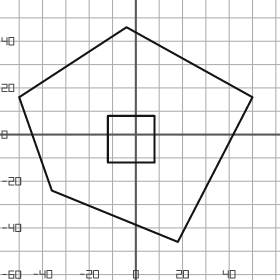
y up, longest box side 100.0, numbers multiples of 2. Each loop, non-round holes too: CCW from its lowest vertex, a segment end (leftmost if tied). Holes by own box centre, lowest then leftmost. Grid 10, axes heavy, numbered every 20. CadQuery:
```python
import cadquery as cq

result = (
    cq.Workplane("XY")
    .moveTo(18.0, -46.0)
    .lineTo(50.0, 16.0)
    .lineTo(-4.0, 46.0)
    .lineTo(-50.0, 16.0)
    .lineTo(-36.0, -24.0)
    .close()
    .moveTo(-12.0, -12.0)
    .lineTo(8.0, -12.0)
    .lineTo(8.0, 8.0)
    .lineTo(-12.0, 8.0)
    .close()
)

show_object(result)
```